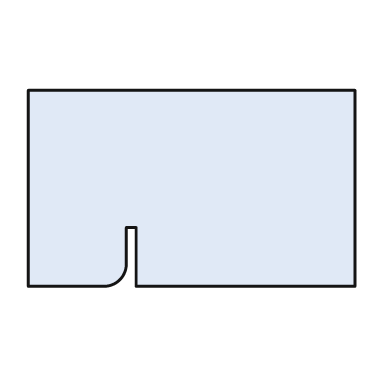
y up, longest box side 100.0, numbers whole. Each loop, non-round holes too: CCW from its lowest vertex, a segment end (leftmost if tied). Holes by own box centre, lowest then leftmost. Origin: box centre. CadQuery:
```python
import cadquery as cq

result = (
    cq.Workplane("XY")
    .moveTo(-50.0, -30.0)
    .lineTo(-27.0, -30.0)
    .threePointArc((-22.0, -28.0), (-20.0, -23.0))
    .lineTo(-20.0, -12.0)
    .lineTo(-17.0, -12.0)
    .lineTo(-17.0, -30.0)
    .lineTo(50.0, -30.0)
    .lineTo(50.0, 30.0)
    .lineTo(-50.0, 30.0)
    .close()
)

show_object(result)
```